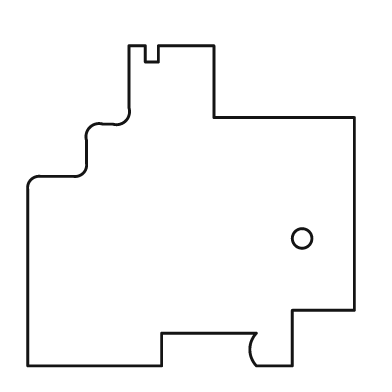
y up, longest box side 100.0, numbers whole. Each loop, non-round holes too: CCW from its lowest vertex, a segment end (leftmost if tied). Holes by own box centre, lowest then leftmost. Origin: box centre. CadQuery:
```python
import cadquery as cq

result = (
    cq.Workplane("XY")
    .moveTo(-50.0, -49.0)
    .lineTo(-9.0, -49.0)
    .lineTo(-9.0, -39.0)
    .lineTo(20.0, -39.0)
    .threePointArc((18.0, -44.0), (20.0, -49.0))
    .lineTo(31.0, -49.0)
    .lineTo(31.0, -32.0)
    .lineTo(50.0, -32.0)
    .lineTo(50.0, 27.0)
    .lineTo(7.0, 27.0)
    .lineTo(7.0, 49.0)
    .lineTo(-10.0, 49.0)
    .lineTo(-10.0, 44.0)
    .lineTo(-14.0, 44.0)
    .lineTo(-14.0, 49.0)
    .lineTo(-19.0, 49.0)
    .lineTo(-19.0, 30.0)
    .threePointArc((-20.0, 26.0), (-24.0, 25.0))
    .lineTo(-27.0, 25.0)
    .threePointArc((-31.0, 24.0), (-32.0, 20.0))
    .lineTo(-32.0, 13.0)
    .threePointArc((-33.0, 10.0), (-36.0, 9.0))
    .lineTo(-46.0, 9.0)
    .threePointArc((-49.0, 8.0), (-50.0, 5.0))
    .close()
    .moveTo(34.0, -10.0)
    .circle(3.0)
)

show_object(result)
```